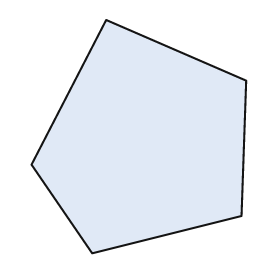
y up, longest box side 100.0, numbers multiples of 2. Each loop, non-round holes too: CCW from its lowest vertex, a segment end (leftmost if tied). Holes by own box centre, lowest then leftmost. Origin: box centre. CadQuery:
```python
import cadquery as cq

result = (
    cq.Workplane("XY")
    .moveTo(-20.0, -50.0)
    .lineTo(44.0, -34.0)
    .lineTo(46.0, 24.0)
    .lineTo(-14.0, 50.0)
    .lineTo(-46.0, -12.0)
    .close()
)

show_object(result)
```